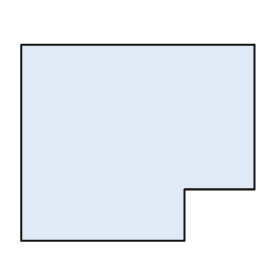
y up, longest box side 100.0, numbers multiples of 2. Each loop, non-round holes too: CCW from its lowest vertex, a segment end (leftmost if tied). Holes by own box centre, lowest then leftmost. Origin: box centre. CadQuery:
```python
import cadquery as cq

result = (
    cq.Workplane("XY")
    .moveTo(-50.0, -42.0)
    .lineTo(20.0, -42.0)
    .lineTo(20.0, -20.0)
    .lineTo(50.0, -20.0)
    .lineTo(50.0, 42.0)
    .lineTo(-50.0, 42.0)
    .close()
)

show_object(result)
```